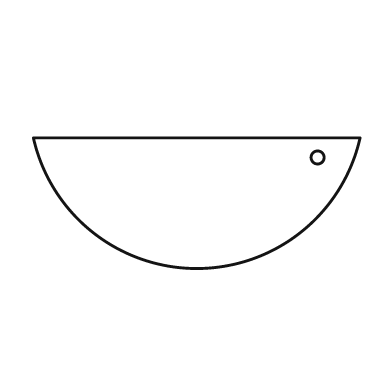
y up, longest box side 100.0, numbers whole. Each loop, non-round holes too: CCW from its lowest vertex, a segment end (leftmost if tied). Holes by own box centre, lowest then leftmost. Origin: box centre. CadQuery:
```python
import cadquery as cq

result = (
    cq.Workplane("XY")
    .moveTo(-50.0, 20.0)
    .threePointArc((0.0, -20.0), (50.0, 20.0))
    .close()
    .moveTo(37.0, 14.0)
    .circle(2.0)
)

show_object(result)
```